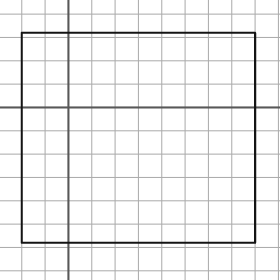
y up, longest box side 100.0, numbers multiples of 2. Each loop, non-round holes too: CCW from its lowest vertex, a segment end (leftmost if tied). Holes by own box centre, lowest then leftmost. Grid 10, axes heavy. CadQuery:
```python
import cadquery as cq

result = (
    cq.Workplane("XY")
    .moveTo(-20.0, -58.0)
    .lineTo(80.0, -58.0)
    .lineTo(80.0, 32.0)
    .lineTo(-20.0, 32.0)
    .close()
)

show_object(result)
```